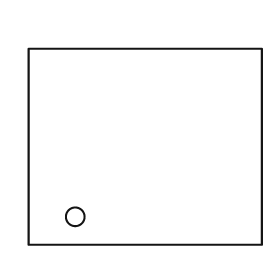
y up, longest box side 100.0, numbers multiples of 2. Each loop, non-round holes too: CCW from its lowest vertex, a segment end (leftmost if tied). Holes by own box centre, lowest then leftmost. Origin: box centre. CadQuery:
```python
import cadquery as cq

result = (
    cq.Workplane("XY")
    .moveTo(-50.0, -42.0)
    .lineTo(50.0, -42.0)
    .lineTo(50.0, 42.0)
    .lineTo(-50.0, 42.0)
    .close()
    .moveTo(-30.0, -30.0)
    .circle(4.0)
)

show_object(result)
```